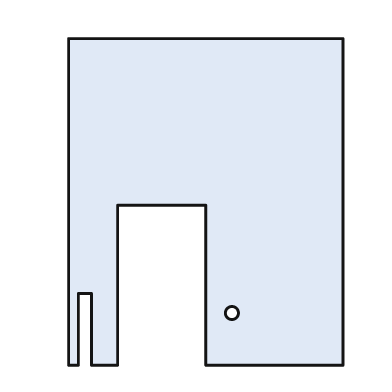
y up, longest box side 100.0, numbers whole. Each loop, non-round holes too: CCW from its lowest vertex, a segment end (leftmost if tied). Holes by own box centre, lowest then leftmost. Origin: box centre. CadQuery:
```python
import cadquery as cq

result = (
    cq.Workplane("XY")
    .moveTo(-42.0, -50.0)
    .lineTo(-39.0, -50.0)
    .lineTo(-39.0, -28.0)
    .lineTo(-35.0, -28.0)
    .lineTo(-35.0, -50.0)
    .lineTo(-27.0, -50.0)
    .lineTo(-27.0, -1.0)
    .lineTo(0.0, -1.0)
    .lineTo(0.0, -50.0)
    .lineTo(42.0, -50.0)
    .lineTo(42.0, 50.0)
    .lineTo(-42.0, 50.0)
    .close()
    .moveTo(8.0, -34.0)
    .circle(2.0)
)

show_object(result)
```